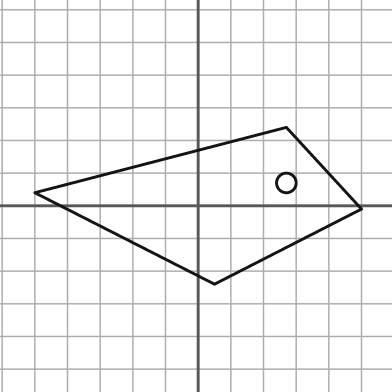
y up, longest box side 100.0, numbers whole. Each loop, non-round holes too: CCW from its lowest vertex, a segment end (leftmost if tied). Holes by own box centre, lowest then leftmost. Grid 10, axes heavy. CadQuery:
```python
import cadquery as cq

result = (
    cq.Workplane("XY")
    .moveTo(5.0, -24.0)
    .lineTo(50.0, -1.0)
    .lineTo(27.0, 24.0)
    .lineTo(-50.0, 4.0)
    .close()
    .moveTo(27.0, 7.0)
    .circle(3.0)
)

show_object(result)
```